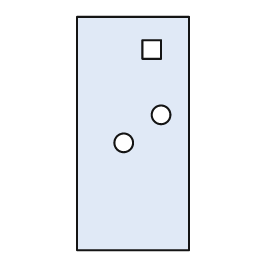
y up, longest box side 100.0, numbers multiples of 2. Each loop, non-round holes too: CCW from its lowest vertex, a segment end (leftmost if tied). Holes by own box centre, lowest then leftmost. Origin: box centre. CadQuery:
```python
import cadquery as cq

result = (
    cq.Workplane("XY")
    .moveTo(-24.0, -50.0)
    .lineTo(24.0, -50.0)
    .lineTo(24.0, 50.0)
    .lineTo(-24.0, 50.0)
    .close()
    .moveTo(-4.0, -4.0)
    .circle(4.0)
    .moveTo(12.0, 8.0)
    .circle(4.0)
    .moveTo(4.0, 32.0)
    .lineTo(12.0, 32.0)
    .lineTo(12.0, 40.0)
    .lineTo(4.0, 40.0)
    .close()
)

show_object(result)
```